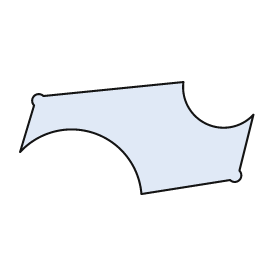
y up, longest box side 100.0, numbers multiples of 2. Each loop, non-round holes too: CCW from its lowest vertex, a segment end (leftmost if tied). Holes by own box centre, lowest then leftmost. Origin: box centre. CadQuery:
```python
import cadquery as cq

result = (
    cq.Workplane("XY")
    .moveTo(2.0, -24.0)
    .lineTo(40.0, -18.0)
    .threePointArc((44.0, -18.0), (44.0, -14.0))
    .lineTo(50.0, 10.0)
    .threePointArc((30.0, 6.0), (20.0, 24.0))
    .lineTo(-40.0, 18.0)
    .threePointArc((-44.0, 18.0), (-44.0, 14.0))
    .lineTo(-50.0, -6.0)
    .threePointArc((-18.0, 2.0), (2.0, -24.0))
    .close()
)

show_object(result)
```